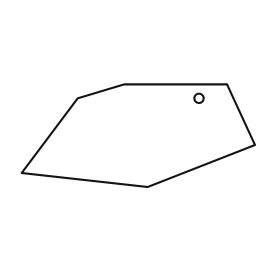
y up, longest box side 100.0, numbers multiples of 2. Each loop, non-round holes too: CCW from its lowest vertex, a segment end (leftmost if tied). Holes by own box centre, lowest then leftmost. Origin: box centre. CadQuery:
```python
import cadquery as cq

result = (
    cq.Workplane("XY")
    .moveTo(4.0, -22.0)
    .lineTo(50.0, -4.0)
    .lineTo(38.0, 22.0)
    .lineTo(-6.0, 22.0)
    .lineTo(-26.0, 16.0)
    .lineTo(-50.0, -16.0)
    .close()
    .moveTo(26.0, 16.0)
    .circle(2.0)
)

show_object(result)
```